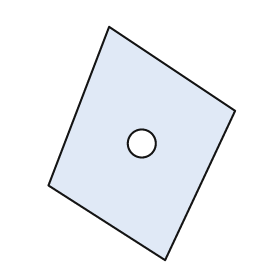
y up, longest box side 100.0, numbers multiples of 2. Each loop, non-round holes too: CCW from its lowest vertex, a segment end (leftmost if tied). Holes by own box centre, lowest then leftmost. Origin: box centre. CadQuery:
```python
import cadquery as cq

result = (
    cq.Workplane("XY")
    .moveTo(10.0, -50.0)
    .lineTo(40.0, 14.0)
    .lineTo(-14.0, 50.0)
    .lineTo(-40.0, -18.0)
    .close()
    .moveTo(0.0, 0.0)
    .circle(6.0)
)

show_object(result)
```